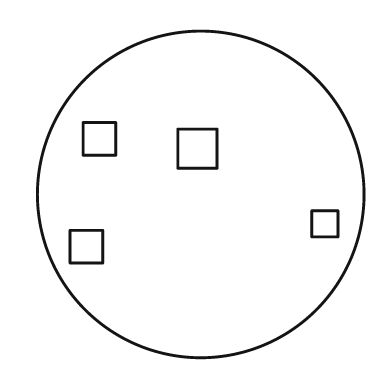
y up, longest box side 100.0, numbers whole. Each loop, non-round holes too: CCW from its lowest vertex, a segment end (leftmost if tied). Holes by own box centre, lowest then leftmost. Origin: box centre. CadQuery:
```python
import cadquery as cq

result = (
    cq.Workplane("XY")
    .moveTo(0.0, 0.0)
    .circle(50.0)
    .moveTo(-40.0, -21.0)
    .lineTo(-30.0, -21.0)
    .lineTo(-30.0, -11.0)
    .lineTo(-40.0, -11.0)
    .close()
    .moveTo(34.0, -13.0)
    .lineTo(42.0, -13.0)
    .lineTo(42.0, -5.0)
    .lineTo(34.0, -5.0)
    .close()
    .moveTo(-7.0, 8.0)
    .lineTo(5.0, 8.0)
    .lineTo(5.0, 20.0)
    .lineTo(-7.0, 20.0)
    .close()
    .moveTo(-36.0, 12.0)
    .lineTo(-26.0, 12.0)
    .lineTo(-26.0, 22.0)
    .lineTo(-36.0, 22.0)
    .close()
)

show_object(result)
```